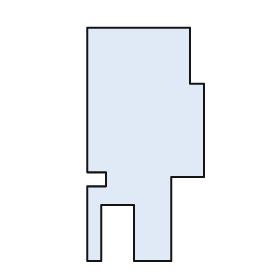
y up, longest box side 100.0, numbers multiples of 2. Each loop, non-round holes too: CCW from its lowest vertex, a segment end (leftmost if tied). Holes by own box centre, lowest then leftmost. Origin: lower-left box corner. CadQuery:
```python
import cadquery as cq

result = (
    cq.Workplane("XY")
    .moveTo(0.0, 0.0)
    .lineTo(6.0, 0.0)
    .lineTo(6.0, 24.0)
    .lineTo(20.0, 24.0)
    .lineTo(20.0, 0.0)
    .lineTo(36.0, 0.0)
    .lineTo(36.0, 36.0)
    .lineTo(50.0, 36.0)
    .lineTo(50.0, 76.0)
    .lineTo(44.0, 76.0)
    .lineTo(44.0, 100.0)
    .lineTo(0.0, 100.0)
    .lineTo(0.0, 38.0)
    .lineTo(8.0, 38.0)
    .lineTo(8.0, 32.0)
    .lineTo(0.0, 32.0)
    .close()
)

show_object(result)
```